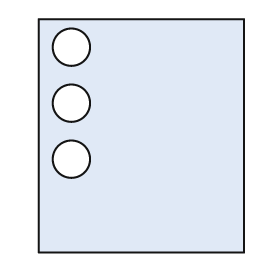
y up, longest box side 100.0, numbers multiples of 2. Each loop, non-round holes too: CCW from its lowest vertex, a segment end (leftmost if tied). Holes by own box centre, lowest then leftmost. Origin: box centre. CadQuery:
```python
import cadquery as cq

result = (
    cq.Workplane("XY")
    .moveTo(-44.0, -50.0)
    .lineTo(44.0, -50.0)
    .lineTo(44.0, 50.0)
    .lineTo(-44.0, 50.0)
    .close()
    .moveTo(-30.0, -10.0)
    .circle(8.0)
    .moveTo(-30.0, 14.0)
    .circle(8.0)
    .moveTo(-30.0, 38.0)
    .circle(8.0)
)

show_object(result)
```